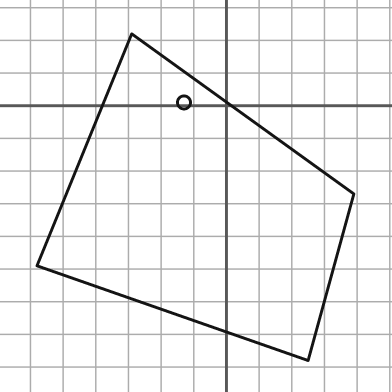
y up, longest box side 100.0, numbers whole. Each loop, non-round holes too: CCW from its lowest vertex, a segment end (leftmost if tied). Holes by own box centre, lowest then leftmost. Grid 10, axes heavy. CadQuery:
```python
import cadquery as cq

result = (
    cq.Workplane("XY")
    .moveTo(25.0, -78.0)
    .lineTo(39.0, -27.0)
    .lineTo(-29.0, 22.0)
    .lineTo(-58.0, -49.0)
    .close()
    .moveTo(-13.0, 1.0)
    .circle(2.0)
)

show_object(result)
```